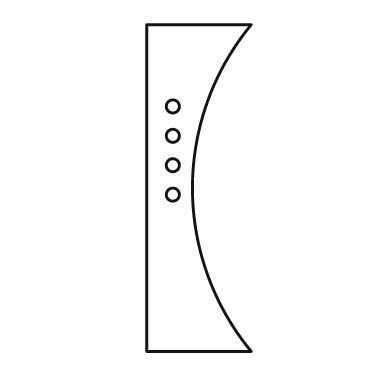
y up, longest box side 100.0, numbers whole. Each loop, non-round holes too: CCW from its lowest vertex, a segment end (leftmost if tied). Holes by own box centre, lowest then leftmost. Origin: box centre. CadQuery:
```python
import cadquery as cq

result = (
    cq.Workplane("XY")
    .moveTo(-16.0, -50.0)
    .lineTo(16.0, -50.0)
    .threePointArc((-2.0, 0.0), (16.0, 50.0))
    .lineTo(-16.0, 50.0)
    .close()
    .moveTo(-8.0, -2.0)
    .circle(2.0)
    .moveTo(-8.0, 7.0)
    .circle(2.0)
    .moveTo(-8.0, 16.0)
    .circle(2.0)
    .moveTo(-8.0, 25.0)
    .circle(2.0)
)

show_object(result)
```